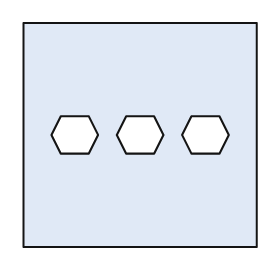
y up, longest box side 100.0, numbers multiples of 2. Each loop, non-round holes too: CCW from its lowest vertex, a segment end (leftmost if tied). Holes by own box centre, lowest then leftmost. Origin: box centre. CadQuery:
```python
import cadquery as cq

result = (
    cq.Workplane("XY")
    .moveTo(-50.0, -48.0)
    .lineTo(50.0, -48.0)
    .lineTo(50.0, 48.0)
    .lineTo(-50.0, 48.0)
    .close()
    .moveTo(-34.0, -8.0)
    .lineTo(-22.0, -8.0)
    .lineTo(-18.0, 0.0)
    .lineTo(-22.0, 8.0)
    .lineTo(-34.0, 8.0)
    .lineTo(-38.0, 0.0)
    .close()
    .moveTo(-6.0, -8.0)
    .lineTo(6.0, -8.0)
    .lineTo(10.0, 0.0)
    .lineTo(6.0, 8.0)
    .lineTo(-6.0, 8.0)
    .lineTo(-10.0, 0.0)
    .close()
    .moveTo(22.0, -8.0)
    .lineTo(34.0, -8.0)
    .lineTo(38.0, 0.0)
    .lineTo(34.0, 8.0)
    .lineTo(22.0, 8.0)
    .lineTo(18.0, 0.0)
    .close()
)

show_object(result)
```